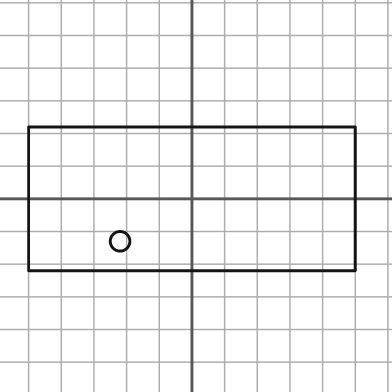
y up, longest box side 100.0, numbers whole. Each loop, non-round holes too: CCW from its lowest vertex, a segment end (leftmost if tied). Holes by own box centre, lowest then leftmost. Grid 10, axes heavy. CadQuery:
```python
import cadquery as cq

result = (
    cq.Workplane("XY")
    .moveTo(-50.0, -22.0)
    .lineTo(50.0, -22.0)
    .lineTo(50.0, 22.0)
    .lineTo(-50.0, 22.0)
    .close()
    .moveTo(-22.0, -13.0)
    .circle(3.0)
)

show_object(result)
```